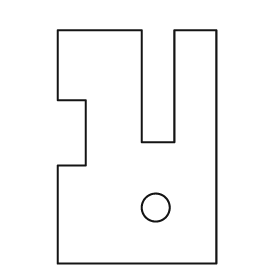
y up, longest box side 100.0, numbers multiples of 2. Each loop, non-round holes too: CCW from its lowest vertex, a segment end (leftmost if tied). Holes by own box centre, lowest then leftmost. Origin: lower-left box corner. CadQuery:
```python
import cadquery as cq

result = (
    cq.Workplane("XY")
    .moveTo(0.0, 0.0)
    .lineTo(68.0, 0.0)
    .lineTo(68.0, 100.0)
    .lineTo(50.0, 100.0)
    .lineTo(50.0, 52.0)
    .lineTo(36.0, 52.0)
    .lineTo(36.0, 100.0)
    .lineTo(0.0, 100.0)
    .lineTo(0.0, 70.0)
    .lineTo(12.0, 70.0)
    .lineTo(12.0, 42.0)
    .lineTo(0.0, 42.0)
    .close()
    .moveTo(42.0, 24.0)
    .circle(6.0)
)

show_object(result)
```